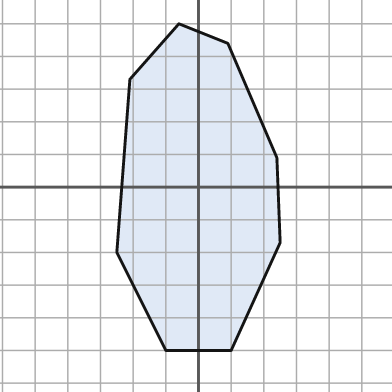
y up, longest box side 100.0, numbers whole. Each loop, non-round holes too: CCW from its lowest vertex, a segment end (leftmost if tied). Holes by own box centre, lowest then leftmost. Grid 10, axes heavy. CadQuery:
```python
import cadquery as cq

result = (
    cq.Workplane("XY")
    .moveTo(-10.0, -50.0)
    .lineTo(10.0, -50.0)
    .lineTo(25.0, -17.0)
    .lineTo(24.0, 9.0)
    .lineTo(9.0, 44.0)
    .lineTo(-6.0, 50.0)
    .lineTo(-21.0, 33.0)
    .lineTo(-25.0, -20.0)
    .close()
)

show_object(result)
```